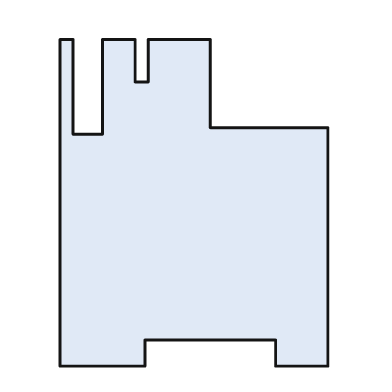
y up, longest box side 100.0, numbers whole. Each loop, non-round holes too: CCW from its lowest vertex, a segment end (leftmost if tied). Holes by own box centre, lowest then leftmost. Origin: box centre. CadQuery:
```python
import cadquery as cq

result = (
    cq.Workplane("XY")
    .moveTo(-41.0, -50.0)
    .lineTo(-15.0, -50.0)
    .lineTo(-15.0, -42.0)
    .lineTo(25.0, -42.0)
    .lineTo(25.0, -50.0)
    .lineTo(41.0, -50.0)
    .lineTo(41.0, 23.0)
    .lineTo(5.0, 23.0)
    .lineTo(5.0, 50.0)
    .lineTo(-14.0, 50.0)
    .lineTo(-14.0, 37.0)
    .lineTo(-18.0, 37.0)
    .lineTo(-18.0, 50.0)
    .lineTo(-28.0, 50.0)
    .lineTo(-28.0, 21.0)
    .lineTo(-37.0, 21.0)
    .lineTo(-37.0, 50.0)
    .lineTo(-41.0, 50.0)
    .close()
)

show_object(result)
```